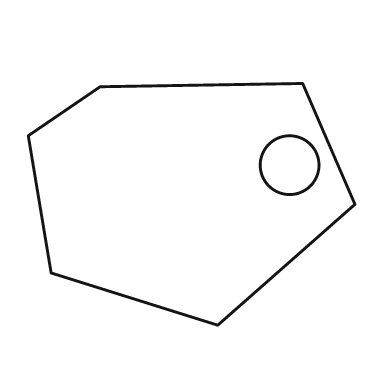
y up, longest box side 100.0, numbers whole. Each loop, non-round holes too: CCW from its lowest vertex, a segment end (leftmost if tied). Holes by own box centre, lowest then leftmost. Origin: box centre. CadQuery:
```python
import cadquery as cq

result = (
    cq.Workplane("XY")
    .moveTo(8.0, -37.0)
    .lineTo(50.0, 0.0)
    .lineTo(34.0, 37.0)
    .lineTo(-28.0, 36.0)
    .lineTo(-50.0, 21.0)
    .lineTo(-43.0, -21.0)
    .close()
    .moveTo(30.0, 12.0)
    .circle(9.0)
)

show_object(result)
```